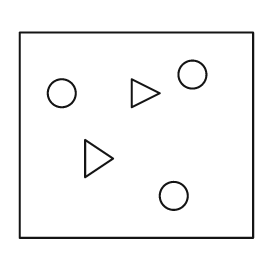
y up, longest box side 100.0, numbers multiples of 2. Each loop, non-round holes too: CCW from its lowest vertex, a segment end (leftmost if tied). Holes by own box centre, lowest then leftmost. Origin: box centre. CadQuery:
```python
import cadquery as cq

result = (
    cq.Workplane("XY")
    .moveTo(-50.0, -44.0)
    .lineTo(50.0, -44.0)
    .lineTo(50.0, 44.0)
    .lineTo(-50.0, 44.0)
    .close()
    .moveTo(16.0, -26.0)
    .circle(6.0)
    .moveTo(-22.0, -18.0)
    .lineTo(-10.0, -10.0)
    .lineTo(-22.0, -2.0)
    .close()
    .moveTo(-32.0, 18.0)
    .circle(6.0)
    .moveTo(-2.0, 12.0)
    .lineTo(10.0, 18.0)
    .lineTo(-2.0, 24.0)
    .close()
    .moveTo(24.0, 26.0)
    .circle(6.0)
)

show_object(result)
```